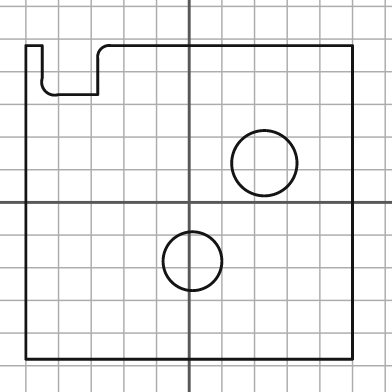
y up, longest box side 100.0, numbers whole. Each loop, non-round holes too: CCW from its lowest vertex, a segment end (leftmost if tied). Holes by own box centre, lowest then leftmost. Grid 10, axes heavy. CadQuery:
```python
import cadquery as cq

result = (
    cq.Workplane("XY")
    .moveTo(-50.0, -48.0)
    .lineTo(50.0, -48.0)
    .lineTo(50.0, 48.0)
    .lineTo(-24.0, 48.0)
    .threePointArc((-27.0, 47.0), (-28.0, 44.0))
    .lineTo(-28.0, 33.0)
    .lineTo(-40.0, 33.0)
    .threePointArc((-44.0, 34.0), (-45.0, 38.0))
    .lineTo(-45.0, 48.0)
    .lineTo(-50.0, 48.0)
    .close()
    .moveTo(1.0, -18.0)
    .circle(9.0)
    .moveTo(23.0, 12.0)
    .circle(10.0)
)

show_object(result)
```